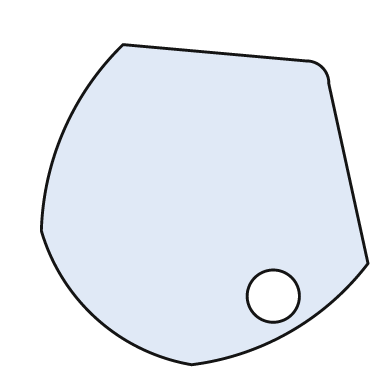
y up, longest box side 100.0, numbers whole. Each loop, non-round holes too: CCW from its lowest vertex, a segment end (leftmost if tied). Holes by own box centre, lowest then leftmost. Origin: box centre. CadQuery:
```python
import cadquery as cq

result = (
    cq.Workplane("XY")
    .moveTo(-4.0, -49.0)
    .threePointArc((26.0, -39.0), (50.0, -18.0))
    .lineTo(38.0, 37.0)
    .threePointArc((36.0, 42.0), (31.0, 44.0))
    .lineTo(-25.0, 49.0)
    .threePointArc((-43.0, 23.0), (-50.0, -8.0))
    .threePointArc((-33.0, -35.0), (-4.0, -49.0))
    .close()
    .moveTo(21.0, -28.0)
    .circle(8.0)
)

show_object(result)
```